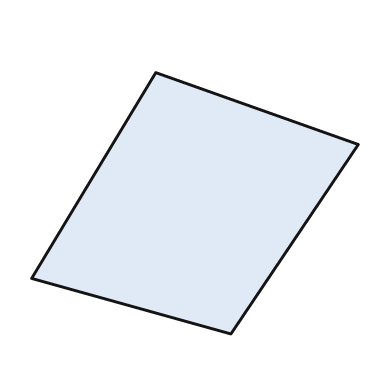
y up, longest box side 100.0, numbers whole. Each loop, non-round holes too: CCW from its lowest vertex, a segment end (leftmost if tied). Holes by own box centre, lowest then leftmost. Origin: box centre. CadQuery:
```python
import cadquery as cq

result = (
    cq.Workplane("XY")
    .moveTo(11.0, -40.0)
    .lineTo(50.0, 18.0)
    .lineTo(-12.0, 40.0)
    .lineTo(-50.0, -23.0)
    .close()
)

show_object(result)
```